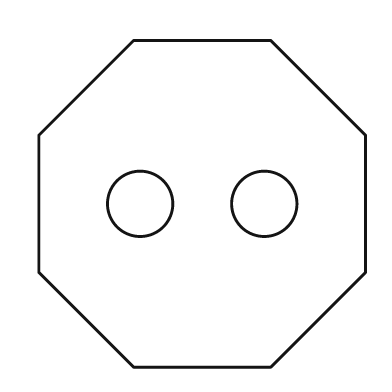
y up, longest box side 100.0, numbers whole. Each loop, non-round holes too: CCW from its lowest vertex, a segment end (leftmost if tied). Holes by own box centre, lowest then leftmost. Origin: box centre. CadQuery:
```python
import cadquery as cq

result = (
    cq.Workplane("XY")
    .moveTo(-21.0, -50.0)
    .lineTo(21.0, -50.0)
    .lineTo(50.0, -21.0)
    .lineTo(50.0, 21.0)
    .lineTo(21.0, 50.0)
    .lineTo(-21.0, 50.0)
    .lineTo(-50.0, 21.0)
    .lineTo(-50.0, -21.0)
    .close()
    .moveTo(-19.0, 0.0)
    .circle(10.0)
    .moveTo(19.0, 0.0)
    .circle(10.0)
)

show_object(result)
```